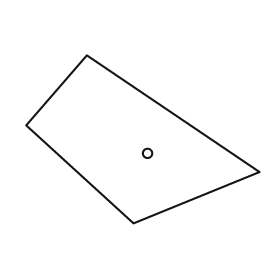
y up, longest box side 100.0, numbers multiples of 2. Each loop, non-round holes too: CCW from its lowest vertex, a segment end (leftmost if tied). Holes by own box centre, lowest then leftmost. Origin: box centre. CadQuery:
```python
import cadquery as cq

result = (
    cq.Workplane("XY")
    .moveTo(-4.0, -36.0)
    .lineTo(50.0, -14.0)
    .lineTo(-24.0, 36.0)
    .lineTo(-50.0, 6.0)
    .close()
    .moveTo(2.0, -6.0)
    .circle(2.0)
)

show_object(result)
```